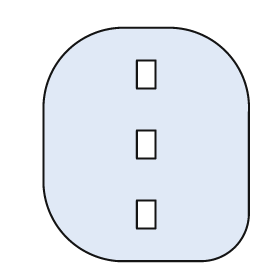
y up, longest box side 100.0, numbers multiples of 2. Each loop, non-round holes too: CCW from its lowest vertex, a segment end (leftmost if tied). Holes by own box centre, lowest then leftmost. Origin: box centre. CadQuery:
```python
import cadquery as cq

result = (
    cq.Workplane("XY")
    .moveTo(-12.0, -50.0)
    .lineTo(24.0, -50.0)
    .threePointArc((38.0, -44.0), (44.0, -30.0))
    .lineTo(44.0, 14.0)
    .threePointArc((34.0, 40.0), (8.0, 50.0))
    .lineTo(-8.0, 50.0)
    .threePointArc((-34.0, 40.0), (-44.0, 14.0))
    .lineTo(-44.0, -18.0)
    .threePointArc((-34.0, -40.0), (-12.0, -50.0))
    .close()
    .moveTo(-4.0, -36.0)
    .lineTo(4.0, -36.0)
    .lineTo(4.0, -24.0)
    .lineTo(-4.0, -24.0)
    .close()
    .moveTo(-4.0, -6.0)
    .lineTo(4.0, -6.0)
    .lineTo(4.0, 6.0)
    .lineTo(-4.0, 6.0)
    .close()
    .moveTo(-4.0, 24.0)
    .lineTo(4.0, 24.0)
    .lineTo(4.0, 36.0)
    .lineTo(-4.0, 36.0)
    .close()
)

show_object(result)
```